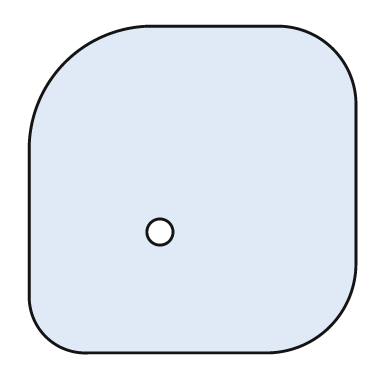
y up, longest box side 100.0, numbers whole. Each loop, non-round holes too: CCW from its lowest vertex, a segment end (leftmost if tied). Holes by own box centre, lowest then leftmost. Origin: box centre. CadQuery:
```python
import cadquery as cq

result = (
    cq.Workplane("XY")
    .moveTo(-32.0, -50.0)
    .lineTo(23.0, -50.0)
    .threePointArc((42.0, -42.0), (50.0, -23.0))
    .lineTo(50.0, 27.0)
    .threePointArc((43.0, 43.0), (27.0, 50.0))
    .lineTo(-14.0, 50.0)
    .threePointArc((-39.0, 39.0), (-50.0, 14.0))
    .lineTo(-50.0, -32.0)
    .threePointArc((-45.0, -45.0), (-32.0, -50.0))
    .close()
    .moveTo(-10.0, -13.0)
    .circle(4.0)
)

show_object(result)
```